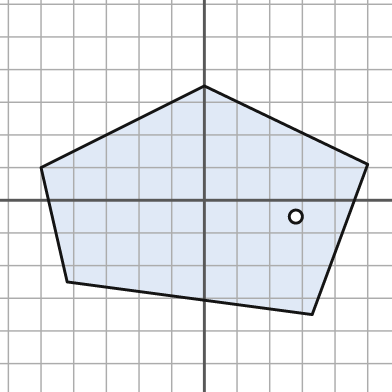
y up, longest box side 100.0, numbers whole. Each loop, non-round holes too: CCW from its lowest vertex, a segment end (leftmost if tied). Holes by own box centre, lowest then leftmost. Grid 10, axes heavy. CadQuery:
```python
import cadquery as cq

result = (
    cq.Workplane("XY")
    .moveTo(33.0, -35.0)
    .lineTo(50.0, 11.0)
    .lineTo(0.0, 35.0)
    .lineTo(-50.0, 10.0)
    .lineTo(-42.0, -25.0)
    .close()
    .moveTo(28.0, -5.0)
    .circle(2.0)
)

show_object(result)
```